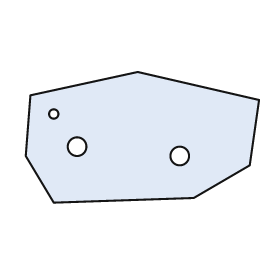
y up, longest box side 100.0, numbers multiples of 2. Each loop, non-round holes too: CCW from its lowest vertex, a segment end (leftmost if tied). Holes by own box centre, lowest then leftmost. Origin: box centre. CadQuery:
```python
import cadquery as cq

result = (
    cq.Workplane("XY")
    .moveTo(-38.0, -28.0)
    .lineTo(22.0, -26.0)
    .lineTo(46.0, -12.0)
    .lineTo(50.0, 16.0)
    .lineTo(-2.0, 28.0)
    .lineTo(-48.0, 18.0)
    .lineTo(-50.0, -8.0)
    .close()
    .moveTo(16.0, -8.0)
    .circle(4.0)
    .moveTo(-28.0, -4.0)
    .circle(4.0)
    .moveTo(-38.0, 10.0)
    .circle(2.0)
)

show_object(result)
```